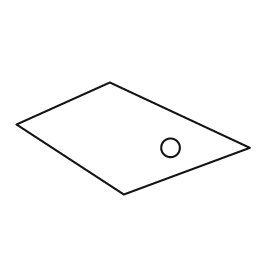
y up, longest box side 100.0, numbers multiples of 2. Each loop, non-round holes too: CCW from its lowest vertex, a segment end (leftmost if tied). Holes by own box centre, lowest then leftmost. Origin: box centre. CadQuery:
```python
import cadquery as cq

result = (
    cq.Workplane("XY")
    .moveTo(-4.0, -24.0)
    .lineTo(50.0, -4.0)
    .lineTo(-10.0, 24.0)
    .lineTo(-50.0, 6.0)
    .close()
    .moveTo(16.0, -4.0)
    .circle(4.0)
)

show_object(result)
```